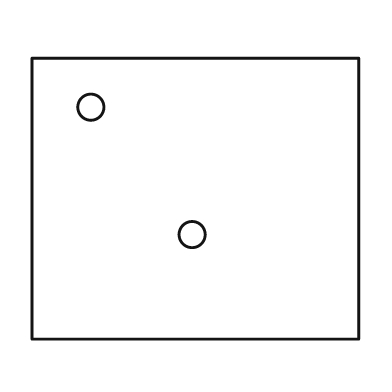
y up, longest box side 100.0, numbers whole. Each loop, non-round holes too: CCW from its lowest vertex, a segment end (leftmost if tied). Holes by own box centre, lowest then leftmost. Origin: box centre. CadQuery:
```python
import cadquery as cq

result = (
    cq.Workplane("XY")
    .moveTo(-50.0, -43.0)
    .lineTo(50.0, -43.0)
    .lineTo(50.0, 43.0)
    .lineTo(-50.0, 43.0)
    .close()
    .moveTo(-1.0, -11.0)
    .circle(4.0)
    .moveTo(-32.0, 28.0)
    .circle(4.0)
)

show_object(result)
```